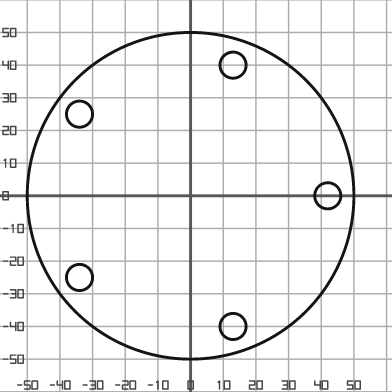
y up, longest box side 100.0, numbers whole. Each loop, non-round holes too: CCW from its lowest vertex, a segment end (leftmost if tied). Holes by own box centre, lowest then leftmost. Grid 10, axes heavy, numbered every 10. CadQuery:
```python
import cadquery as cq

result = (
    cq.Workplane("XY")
    .moveTo(0.0, 0.0)
    .circle(50.0)
    .moveTo(13.0, -40.0)
    .circle(4.0)
    .moveTo(-34.0, -25.0)
    .circle(4.0)
    .moveTo(42.0, 0.0)
    .circle(4.0)
    .moveTo(-34.0, 25.0)
    .circle(4.0)
    .moveTo(13.0, 40.0)
    .circle(4.0)
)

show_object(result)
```